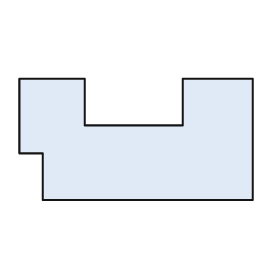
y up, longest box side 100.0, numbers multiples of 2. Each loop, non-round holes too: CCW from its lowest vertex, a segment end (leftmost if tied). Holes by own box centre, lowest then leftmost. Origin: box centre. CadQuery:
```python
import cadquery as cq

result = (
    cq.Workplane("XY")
    .moveTo(-40.0, -26.0)
    .lineTo(50.0, -26.0)
    .lineTo(50.0, 26.0)
    .lineTo(20.0, 26.0)
    .lineTo(20.0, 6.0)
    .lineTo(-22.0, 6.0)
    .lineTo(-22.0, 26.0)
    .lineTo(-50.0, 26.0)
    .lineTo(-50.0, -6.0)
    .lineTo(-40.0, -6.0)
    .close()
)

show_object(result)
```